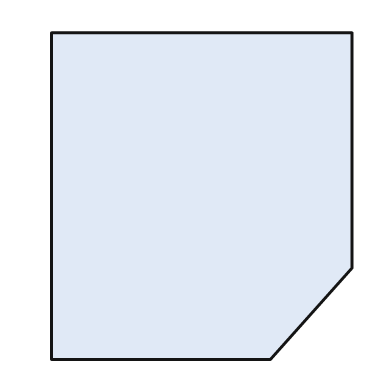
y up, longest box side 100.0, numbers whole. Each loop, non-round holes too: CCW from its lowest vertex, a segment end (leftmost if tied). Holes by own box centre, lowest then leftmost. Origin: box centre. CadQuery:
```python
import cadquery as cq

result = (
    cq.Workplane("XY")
    .moveTo(-46.0, -50.0)
    .lineTo(21.0, -50.0)
    .lineTo(46.0, -22.0)
    .lineTo(46.0, 50.0)
    .lineTo(-46.0, 50.0)
    .close()
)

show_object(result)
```